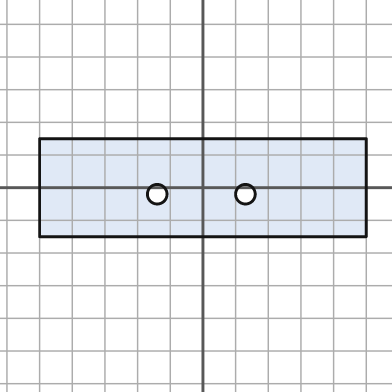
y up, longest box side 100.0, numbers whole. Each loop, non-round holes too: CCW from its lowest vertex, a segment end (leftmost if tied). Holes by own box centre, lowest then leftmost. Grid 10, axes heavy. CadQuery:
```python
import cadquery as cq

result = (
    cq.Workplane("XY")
    .moveTo(-50.0, -15.0)
    .lineTo(50.0, -15.0)
    .lineTo(50.0, 15.0)
    .lineTo(-50.0, 15.0)
    .close()
    .moveTo(-14.0, -2.0)
    .circle(3.0)
    .moveTo(13.0, -2.0)
    .circle(3.0)
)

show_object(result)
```